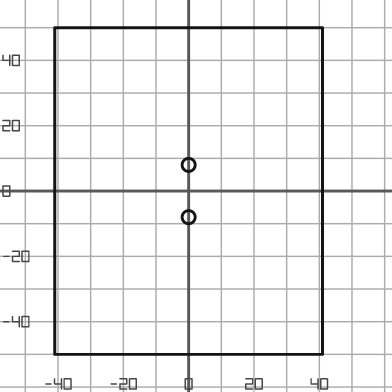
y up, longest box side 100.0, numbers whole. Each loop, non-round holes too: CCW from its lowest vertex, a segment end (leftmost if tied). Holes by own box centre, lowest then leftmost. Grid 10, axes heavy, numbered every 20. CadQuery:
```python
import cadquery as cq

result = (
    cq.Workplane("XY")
    .moveTo(-41.0, -50.0)
    .lineTo(41.0, -50.0)
    .lineTo(41.0, 50.0)
    .lineTo(-41.0, 50.0)
    .close()
    .moveTo(0.0, -8.0)
    .circle(2.0)
    .moveTo(0.0, 8.0)
    .circle(2.0)
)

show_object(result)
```